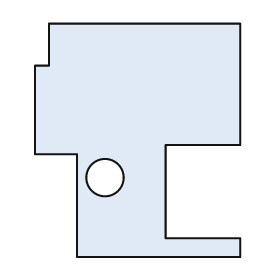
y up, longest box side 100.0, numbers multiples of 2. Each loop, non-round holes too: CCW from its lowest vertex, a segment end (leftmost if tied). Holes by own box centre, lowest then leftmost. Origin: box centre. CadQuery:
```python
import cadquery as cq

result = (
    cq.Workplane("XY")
    .moveTo(-26.0, -50.0)
    .lineTo(44.0, -50.0)
    .lineTo(44.0, -42.0)
    .lineTo(12.0, -42.0)
    .lineTo(12.0, -2.0)
    .lineTo(44.0, -2.0)
    .lineTo(44.0, 50.0)
    .lineTo(-38.0, 50.0)
    .lineTo(-38.0, 32.0)
    .lineTo(-44.0, 32.0)
    .lineTo(-44.0, -6.0)
    .lineTo(-26.0, -6.0)
    .close()
    .moveTo(-14.0, -16.0)
    .circle(8.0)
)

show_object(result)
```